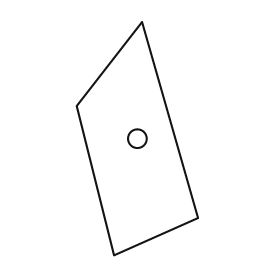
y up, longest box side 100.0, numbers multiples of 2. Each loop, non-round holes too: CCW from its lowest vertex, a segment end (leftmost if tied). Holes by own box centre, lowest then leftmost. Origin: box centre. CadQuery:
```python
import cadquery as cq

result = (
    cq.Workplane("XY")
    .moveTo(-10.0, -50.0)
    .lineTo(26.0, -34.0)
    .lineTo(2.0, 50.0)
    .lineTo(-26.0, 14.0)
    .close()
    .moveTo(0.0, 0.0)
    .circle(4.0)
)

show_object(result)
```